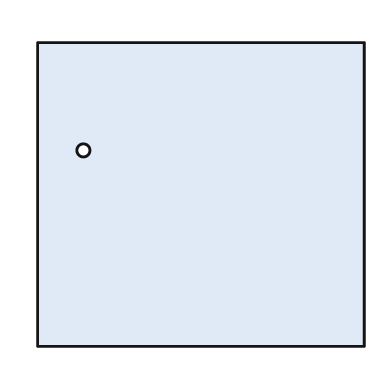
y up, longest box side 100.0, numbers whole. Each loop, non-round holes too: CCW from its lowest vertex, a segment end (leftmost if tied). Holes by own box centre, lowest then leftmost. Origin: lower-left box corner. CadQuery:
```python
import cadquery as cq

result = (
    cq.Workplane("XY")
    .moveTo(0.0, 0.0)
    .lineTo(100.0, 0.0)
    .lineTo(100.0, 93.0)
    .lineTo(0.0, 93.0)
    .close()
    .moveTo(14.0, 60.0)
    .circle(2.0)
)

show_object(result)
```